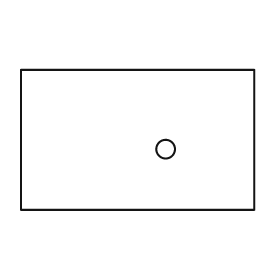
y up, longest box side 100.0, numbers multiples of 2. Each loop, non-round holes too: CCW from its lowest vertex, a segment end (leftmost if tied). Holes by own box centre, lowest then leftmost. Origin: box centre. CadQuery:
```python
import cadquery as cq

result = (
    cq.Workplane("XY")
    .moveTo(-50.0, -30.0)
    .lineTo(50.0, -30.0)
    .lineTo(50.0, 30.0)
    .lineTo(-50.0, 30.0)
    .close()
    .moveTo(12.0, -4.0)
    .circle(4.0)
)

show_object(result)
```